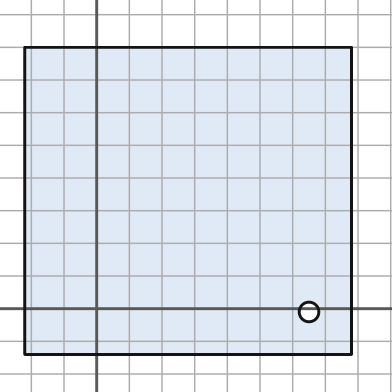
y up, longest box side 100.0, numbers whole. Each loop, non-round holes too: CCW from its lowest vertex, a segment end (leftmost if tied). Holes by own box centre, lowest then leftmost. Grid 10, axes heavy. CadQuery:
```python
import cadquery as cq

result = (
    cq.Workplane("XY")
    .moveTo(-22.0, -14.0)
    .lineTo(78.0, -14.0)
    .lineTo(78.0, 80.0)
    .lineTo(-22.0, 80.0)
    .close()
    .moveTo(65.0, -1.0)
    .circle(3.0)
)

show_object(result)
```